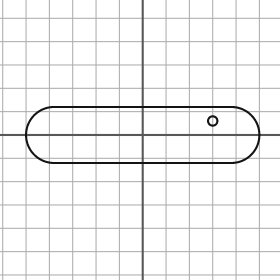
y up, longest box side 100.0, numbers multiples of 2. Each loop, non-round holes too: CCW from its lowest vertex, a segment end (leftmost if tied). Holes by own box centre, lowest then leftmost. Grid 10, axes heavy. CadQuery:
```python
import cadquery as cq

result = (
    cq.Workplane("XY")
    .moveTo(-38.0, -12.0)
    .lineTo(38.0, -12.0)
    .threePointArc((50.0, 0.0), (38.0, 12.0))
    .lineTo(-38.0, 12.0)
    .threePointArc((-50.0, 0.0), (-38.0, -12.0))
    .close()
    .moveTo(30.0, 6.0)
    .circle(2.0)
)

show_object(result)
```